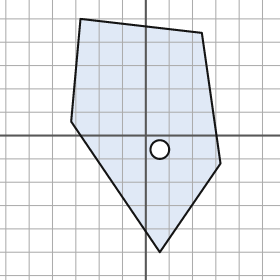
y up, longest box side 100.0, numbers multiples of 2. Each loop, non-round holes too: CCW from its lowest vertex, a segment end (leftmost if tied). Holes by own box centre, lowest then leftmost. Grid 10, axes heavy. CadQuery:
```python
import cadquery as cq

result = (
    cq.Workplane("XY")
    .moveTo(6.0, -50.0)
    .lineTo(32.0, -12.0)
    .lineTo(24.0, 44.0)
    .lineTo(-28.0, 50.0)
    .lineTo(-32.0, 6.0)
    .close()
    .moveTo(6.0, -6.0)
    .circle(4.0)
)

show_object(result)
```